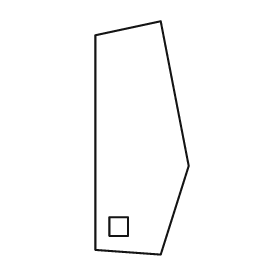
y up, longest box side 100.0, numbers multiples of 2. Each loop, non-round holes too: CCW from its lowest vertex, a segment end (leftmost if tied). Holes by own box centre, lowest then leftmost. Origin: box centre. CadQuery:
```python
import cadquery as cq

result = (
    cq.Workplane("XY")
    .moveTo(8.0, -50.0)
    .lineTo(20.0, -12.0)
    .lineTo(8.0, 50.0)
    .lineTo(-20.0, 44.0)
    .lineTo(-20.0, -48.0)
    .close()
    .moveTo(-14.0, -42.0)
    .lineTo(-6.0, -42.0)
    .lineTo(-6.0, -34.0)
    .lineTo(-14.0, -34.0)
    .close()
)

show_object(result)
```